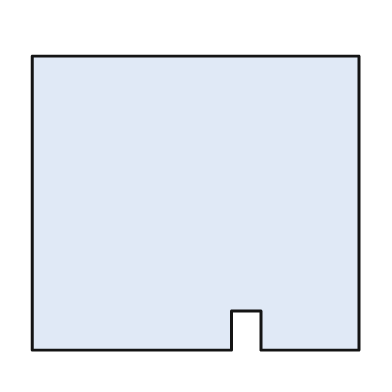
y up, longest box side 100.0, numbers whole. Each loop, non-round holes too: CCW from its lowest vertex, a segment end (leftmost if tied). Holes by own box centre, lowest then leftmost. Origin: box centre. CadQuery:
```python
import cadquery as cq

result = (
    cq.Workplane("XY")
    .moveTo(-50.0, -45.0)
    .lineTo(11.0, -45.0)
    .lineTo(11.0, -33.0)
    .lineTo(20.0, -33.0)
    .lineTo(20.0, -45.0)
    .lineTo(50.0, -45.0)
    .lineTo(50.0, 45.0)
    .lineTo(-50.0, 45.0)
    .close()
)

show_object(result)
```